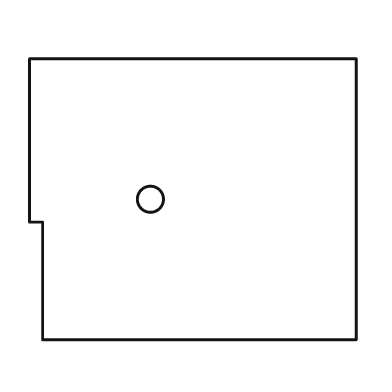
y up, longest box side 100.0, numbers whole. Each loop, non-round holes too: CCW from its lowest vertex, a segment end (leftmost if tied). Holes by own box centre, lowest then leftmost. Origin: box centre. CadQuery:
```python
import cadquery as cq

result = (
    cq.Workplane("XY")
    .moveTo(-46.0, -43.0)
    .lineTo(50.0, -43.0)
    .lineTo(50.0, 43.0)
    .lineTo(-50.0, 43.0)
    .lineTo(-50.0, -7.0)
    .lineTo(-46.0, -7.0)
    .close()
    .moveTo(-13.0, 0.0)
    .circle(4.0)
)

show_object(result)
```